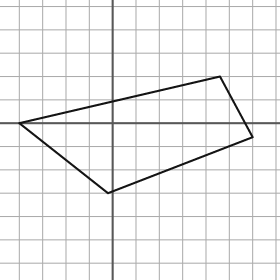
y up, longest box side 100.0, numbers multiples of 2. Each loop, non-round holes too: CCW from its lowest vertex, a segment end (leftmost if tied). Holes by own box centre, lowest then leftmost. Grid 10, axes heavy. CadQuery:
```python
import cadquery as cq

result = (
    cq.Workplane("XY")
    .moveTo(-2.0, -30.0)
    .lineTo(60.0, -6.0)
    .lineTo(46.0, 20.0)
    .lineTo(-40.0, 0.0)
    .close()
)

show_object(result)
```